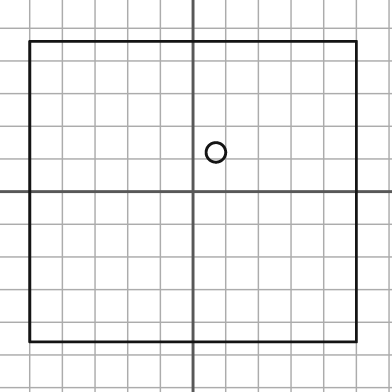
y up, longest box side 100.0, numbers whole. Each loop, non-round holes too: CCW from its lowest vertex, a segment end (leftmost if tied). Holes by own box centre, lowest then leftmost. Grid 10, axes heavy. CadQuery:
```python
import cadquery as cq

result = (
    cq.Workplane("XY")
    .moveTo(-50.0, -46.0)
    .lineTo(50.0, -46.0)
    .lineTo(50.0, 46.0)
    .lineTo(-50.0, 46.0)
    .close()
    .moveTo(7.0, 12.0)
    .circle(3.0)
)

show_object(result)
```